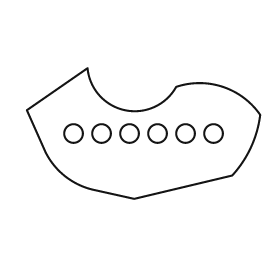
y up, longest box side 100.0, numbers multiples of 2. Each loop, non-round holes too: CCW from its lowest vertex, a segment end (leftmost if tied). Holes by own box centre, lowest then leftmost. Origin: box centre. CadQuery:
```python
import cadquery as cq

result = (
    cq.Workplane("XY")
    .moveTo(-4.0, -28.0)
    .lineTo(38.0, -18.0)
    .threePointArc((46.0, -6.0), (50.0, 8.0))
    .threePointArc((34.0, 20.0), (14.0, 20.0))
    .threePointArc((-8.0, 10.0), (-24.0, 28.0))
    .lineTo(-50.0, 10.0)
    .lineTo(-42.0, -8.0)
    .threePointArc((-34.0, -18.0), (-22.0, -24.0))
    .close()
    .moveTo(-30.0, 0.0)
    .circle(4.0)
    .moveTo(-18.0, 0.0)
    .circle(4.0)
    .moveTo(-6.0, 0.0)
    .circle(4.0)
    .moveTo(6.0, 0.0)
    .circle(4.0)
    .moveTo(18.0, 0.0)
    .circle(4.0)
    .moveTo(30.0, 0.0)
    .circle(4.0)
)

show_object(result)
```